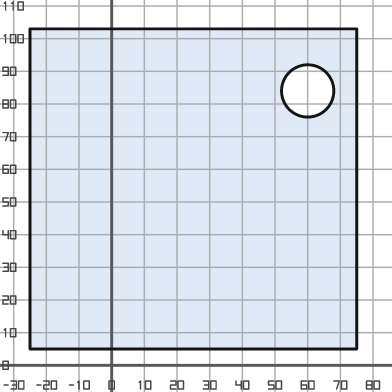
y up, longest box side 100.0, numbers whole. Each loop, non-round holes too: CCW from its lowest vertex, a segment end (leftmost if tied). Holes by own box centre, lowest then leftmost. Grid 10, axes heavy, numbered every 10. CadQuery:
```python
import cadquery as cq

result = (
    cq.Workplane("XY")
    .moveTo(-25.0, 5.0)
    .lineTo(75.0, 5.0)
    .lineTo(75.0, 103.0)
    .lineTo(-25.0, 103.0)
    .close()
    .moveTo(60.0, 84.0)
    .circle(8.0)
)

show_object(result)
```